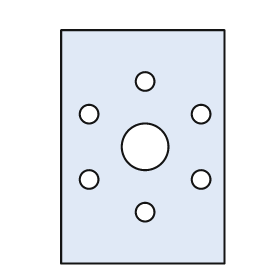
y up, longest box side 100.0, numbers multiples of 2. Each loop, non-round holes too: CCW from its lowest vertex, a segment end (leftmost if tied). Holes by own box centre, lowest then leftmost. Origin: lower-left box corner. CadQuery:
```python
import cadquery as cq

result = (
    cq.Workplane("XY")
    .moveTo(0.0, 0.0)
    .lineTo(70.0, 0.0)
    .lineTo(70.0, 100.0)
    .lineTo(0.0, 100.0)
    .close()
    .moveTo(36.0, 22.0)
    .circle(4.0)
    .moveTo(12.0, 36.0)
    .circle(4.0)
    .moveTo(60.0, 36.0)
    .circle(4.0)
    .moveTo(36.0, 50.0)
    .circle(10.0)
    .moveTo(12.0, 64.0)
    .circle(4.0)
    .moveTo(60.0, 64.0)
    .circle(4.0)
    .moveTo(36.0, 78.0)
    .circle(4.0)
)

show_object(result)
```